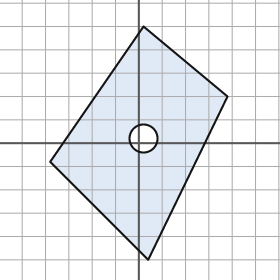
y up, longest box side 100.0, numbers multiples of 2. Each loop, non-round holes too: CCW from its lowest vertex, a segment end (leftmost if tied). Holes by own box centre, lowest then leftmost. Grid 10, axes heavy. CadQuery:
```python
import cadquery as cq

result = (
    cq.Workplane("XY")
    .moveTo(4.0, -50.0)
    .lineTo(38.0, 20.0)
    .lineTo(2.0, 50.0)
    .lineTo(-38.0, -8.0)
    .close()
    .moveTo(2.0, 2.0)
    .circle(6.0)
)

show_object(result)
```